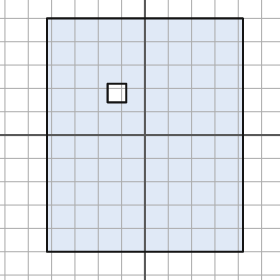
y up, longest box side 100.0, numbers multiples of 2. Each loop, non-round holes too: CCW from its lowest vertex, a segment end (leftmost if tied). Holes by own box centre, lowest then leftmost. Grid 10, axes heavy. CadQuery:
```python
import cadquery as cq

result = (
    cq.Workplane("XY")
    .moveTo(-42.0, -50.0)
    .lineTo(42.0, -50.0)
    .lineTo(42.0, 50.0)
    .lineTo(-42.0, 50.0)
    .close()
    .moveTo(-16.0, 14.0)
    .lineTo(-8.0, 14.0)
    .lineTo(-8.0, 22.0)
    .lineTo(-16.0, 22.0)
    .close()
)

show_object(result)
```